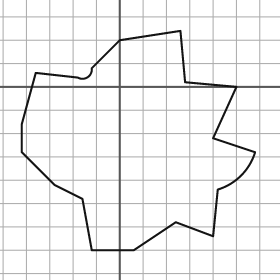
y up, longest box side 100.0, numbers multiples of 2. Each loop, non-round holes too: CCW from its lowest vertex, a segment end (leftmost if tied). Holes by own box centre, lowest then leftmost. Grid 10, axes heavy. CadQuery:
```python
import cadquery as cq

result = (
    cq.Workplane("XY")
    .moveTo(-12.0, -70.0)
    .lineTo(6.0, -70.0)
    .lineTo(24.0, -58.0)
    .lineTo(40.0, -64.0)
    .lineTo(42.0, -44.0)
    .threePointArc((52.0, -38.0), (58.0, -28.0))
    .lineTo(40.0, -22.0)
    .lineTo(50.0, 0.0)
    .lineTo(28.0, 2.0)
    .lineTo(26.0, 24.0)
    .lineTo(0.0, 20.0)
    .lineTo(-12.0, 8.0)
    .threePointArc((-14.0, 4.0), (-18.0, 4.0))
    .lineTo(-36.0, 6.0)
    .lineTo(-42.0, -16.0)
    .lineTo(-42.0, -28.0)
    .lineTo(-28.0, -42.0)
    .lineTo(-16.0, -48.0)
    .close()
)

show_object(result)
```